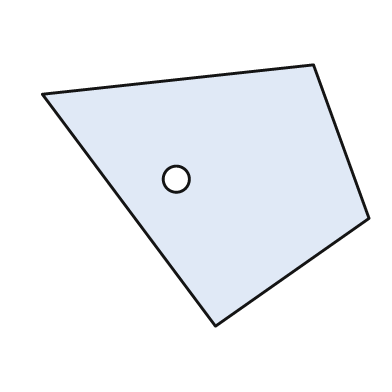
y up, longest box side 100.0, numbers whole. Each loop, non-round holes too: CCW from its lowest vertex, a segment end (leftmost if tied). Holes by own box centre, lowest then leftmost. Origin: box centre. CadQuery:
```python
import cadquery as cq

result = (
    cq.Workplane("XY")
    .moveTo(3.0, -40.0)
    .lineTo(50.0, -7.0)
    .lineTo(33.0, 40.0)
    .lineTo(-50.0, 31.0)
    .close()
    .moveTo(-9.0, 5.0)
    .circle(4.0)
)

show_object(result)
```